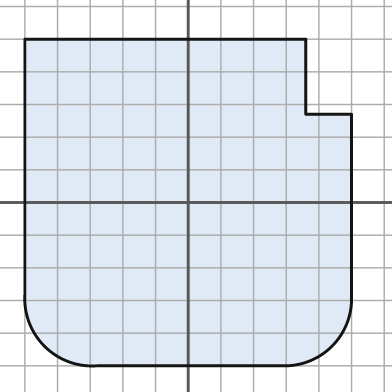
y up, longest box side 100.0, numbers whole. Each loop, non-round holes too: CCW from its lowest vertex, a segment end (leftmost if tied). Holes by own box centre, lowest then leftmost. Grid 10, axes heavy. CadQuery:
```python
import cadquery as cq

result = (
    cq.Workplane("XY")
    .moveTo(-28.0, -50.0)
    .lineTo(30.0, -50.0)
    .threePointArc((44.0, -44.0), (50.0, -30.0))
    .lineTo(50.0, 27.0)
    .lineTo(36.0, 27.0)
    .lineTo(36.0, 50.0)
    .lineTo(-50.0, 50.0)
    .lineTo(-50.0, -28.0)
    .threePointArc((-44.0, -44.0), (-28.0, -50.0))
    .close()
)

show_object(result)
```